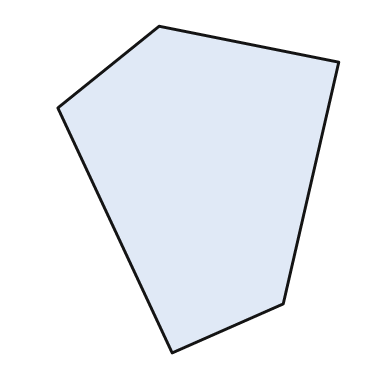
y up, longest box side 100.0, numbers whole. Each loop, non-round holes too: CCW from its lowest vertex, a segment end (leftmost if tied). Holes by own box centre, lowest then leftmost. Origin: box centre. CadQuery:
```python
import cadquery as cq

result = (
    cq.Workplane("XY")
    .moveTo(-8.0, -50.0)
    .lineTo(26.0, -35.0)
    .lineTo(43.0, 39.0)
    .lineTo(-12.0, 50.0)
    .lineTo(-43.0, 25.0)
    .close()
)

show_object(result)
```